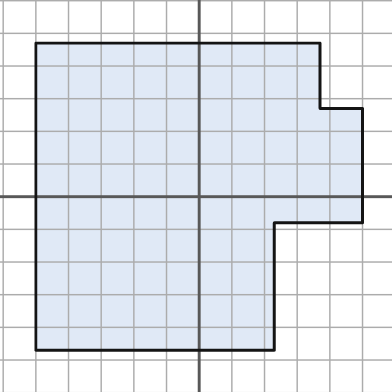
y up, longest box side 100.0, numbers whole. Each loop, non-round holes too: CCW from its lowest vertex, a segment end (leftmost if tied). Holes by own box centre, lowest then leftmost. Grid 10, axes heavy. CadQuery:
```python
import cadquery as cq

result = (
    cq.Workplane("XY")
    .moveTo(-50.0, -47.0)
    .lineTo(23.0, -47.0)
    .lineTo(23.0, -8.0)
    .lineTo(50.0, -8.0)
    .lineTo(50.0, 27.0)
    .lineTo(37.0, 27.0)
    .lineTo(37.0, 47.0)
    .lineTo(-50.0, 47.0)
    .close()
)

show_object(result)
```